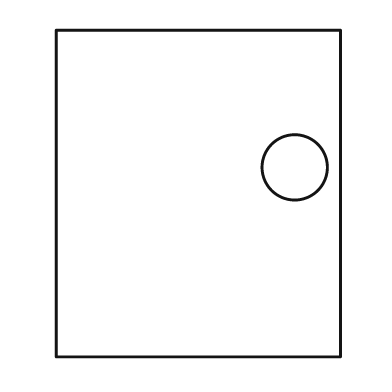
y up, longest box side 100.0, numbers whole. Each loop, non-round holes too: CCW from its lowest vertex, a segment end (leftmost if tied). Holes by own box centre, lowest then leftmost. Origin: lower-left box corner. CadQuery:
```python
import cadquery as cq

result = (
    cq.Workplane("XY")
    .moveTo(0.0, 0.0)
    .lineTo(87.0, 0.0)
    .lineTo(87.0, 100.0)
    .lineTo(0.0, 100.0)
    .close()
    .moveTo(73.0, 58.0)
    .circle(10.0)
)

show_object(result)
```